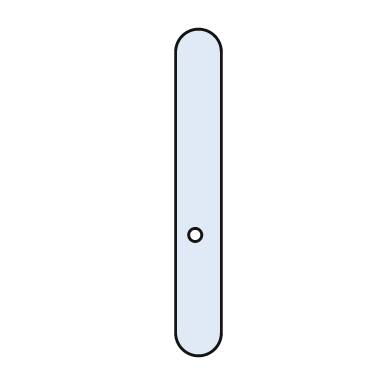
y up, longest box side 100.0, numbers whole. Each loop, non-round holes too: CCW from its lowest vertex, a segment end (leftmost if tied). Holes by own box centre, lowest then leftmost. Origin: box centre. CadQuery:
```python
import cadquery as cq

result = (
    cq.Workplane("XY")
    .moveTo(-7.0, -43.0)
    .threePointArc((0.0, -50.0), (7.0, -43.0))
    .lineTo(7.0, 43.0)
    .threePointArc((0.0, 50.0), (-7.0, 43.0))
    .close()
    .moveTo(-1.0, -13.0)
    .circle(2.0)
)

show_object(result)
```